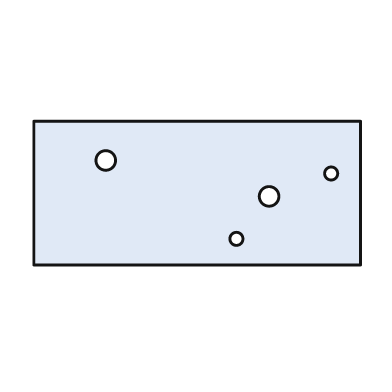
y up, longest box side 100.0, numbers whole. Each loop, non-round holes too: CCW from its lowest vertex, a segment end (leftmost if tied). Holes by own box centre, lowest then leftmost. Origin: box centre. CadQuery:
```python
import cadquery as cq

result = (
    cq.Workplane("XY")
    .moveTo(-50.0, -22.0)
    .lineTo(50.0, -22.0)
    .lineTo(50.0, 22.0)
    .lineTo(-50.0, 22.0)
    .close()
    .moveTo(12.0, -14.0)
    .circle(2.0)
    .moveTo(22.0, -1.0)
    .circle(3.0)
    .moveTo(41.0, 6.0)
    .circle(2.0)
    .moveTo(-28.0, 10.0)
    .circle(3.0)
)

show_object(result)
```